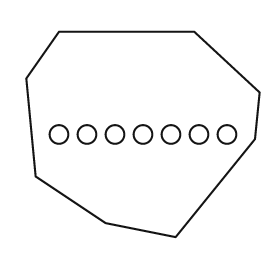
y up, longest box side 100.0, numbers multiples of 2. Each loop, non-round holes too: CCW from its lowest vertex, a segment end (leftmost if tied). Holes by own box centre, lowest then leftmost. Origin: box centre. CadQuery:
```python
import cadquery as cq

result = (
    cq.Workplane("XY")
    .moveTo(14.0, -44.0)
    .lineTo(48.0, -2.0)
    .lineTo(50.0, 18.0)
    .lineTo(22.0, 44.0)
    .lineTo(-36.0, 44.0)
    .lineTo(-50.0, 24.0)
    .lineTo(-46.0, -18.0)
    .lineTo(-16.0, -38.0)
    .close()
    .moveTo(-36.0, 0.0)
    .circle(4.0)
    .moveTo(-24.0, 0.0)
    .circle(4.0)
    .moveTo(-12.0, 0.0)
    .circle(4.0)
    .moveTo(0.0, 0.0)
    .circle(4.0)
    .moveTo(12.0, 0.0)
    .circle(4.0)
    .moveTo(24.0, 0.0)
    .circle(4.0)
    .moveTo(36.0, 0.0)
    .circle(4.0)
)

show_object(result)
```